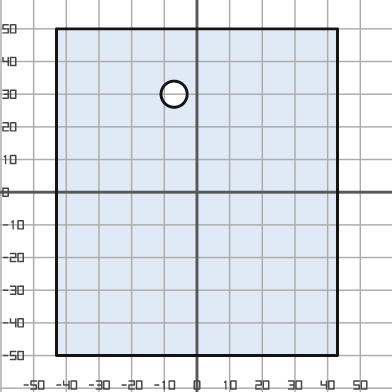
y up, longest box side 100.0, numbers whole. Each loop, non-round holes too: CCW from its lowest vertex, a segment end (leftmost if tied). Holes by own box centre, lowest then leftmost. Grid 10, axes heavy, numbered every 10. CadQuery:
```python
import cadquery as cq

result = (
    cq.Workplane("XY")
    .moveTo(-43.0, -50.0)
    .lineTo(43.0, -50.0)
    .lineTo(43.0, 50.0)
    .lineTo(-43.0, 50.0)
    .close()
    .moveTo(-7.0, 30.0)
    .circle(4.0)
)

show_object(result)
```